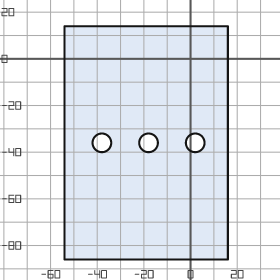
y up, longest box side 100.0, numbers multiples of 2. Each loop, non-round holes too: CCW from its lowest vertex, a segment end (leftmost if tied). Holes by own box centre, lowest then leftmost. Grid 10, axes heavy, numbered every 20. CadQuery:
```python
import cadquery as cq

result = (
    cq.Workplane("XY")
    .moveTo(-54.0, -86.0)
    .lineTo(16.0, -86.0)
    .lineTo(16.0, 14.0)
    .lineTo(-54.0, 14.0)
    .close()
    .moveTo(-38.0, -36.0)
    .circle(4.0)
    .moveTo(-18.0, -36.0)
    .circle(4.0)
    .moveTo(2.0, -36.0)
    .circle(4.0)
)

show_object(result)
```